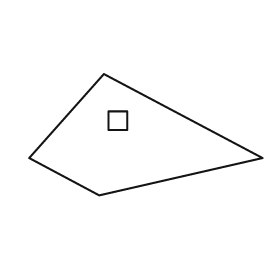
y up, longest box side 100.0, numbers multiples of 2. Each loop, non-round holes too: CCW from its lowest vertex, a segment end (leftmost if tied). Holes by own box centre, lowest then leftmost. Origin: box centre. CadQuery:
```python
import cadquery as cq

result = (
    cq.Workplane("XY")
    .moveTo(-20.0, -26.0)
    .lineTo(50.0, -10.0)
    .lineTo(-18.0, 26.0)
    .lineTo(-50.0, -10.0)
    .close()
    .moveTo(-16.0, 2.0)
    .lineTo(-8.0, 2.0)
    .lineTo(-8.0, 10.0)
    .lineTo(-16.0, 10.0)
    .close()
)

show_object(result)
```